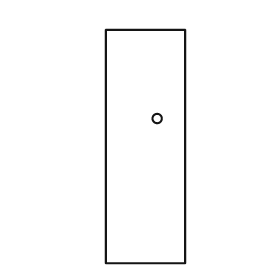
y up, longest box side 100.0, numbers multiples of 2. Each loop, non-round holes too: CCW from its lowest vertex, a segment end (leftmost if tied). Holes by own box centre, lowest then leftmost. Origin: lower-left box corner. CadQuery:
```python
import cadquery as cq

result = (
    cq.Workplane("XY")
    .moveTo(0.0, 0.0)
    .lineTo(34.0, 0.0)
    .lineTo(34.0, 100.0)
    .lineTo(0.0, 100.0)
    .close()
    .moveTo(22.0, 62.0)
    .circle(2.0)
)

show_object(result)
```